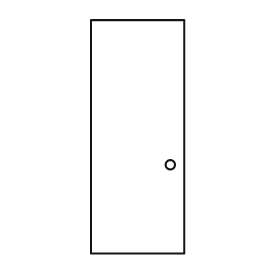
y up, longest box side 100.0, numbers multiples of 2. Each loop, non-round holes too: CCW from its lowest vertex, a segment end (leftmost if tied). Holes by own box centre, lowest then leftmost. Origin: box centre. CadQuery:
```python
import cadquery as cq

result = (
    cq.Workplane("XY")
    .moveTo(-20.0, -50.0)
    .lineTo(20.0, -50.0)
    .lineTo(20.0, 50.0)
    .lineTo(-20.0, 50.0)
    .close()
    .moveTo(14.0, -12.0)
    .circle(2.0)
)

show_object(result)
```